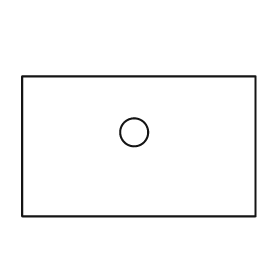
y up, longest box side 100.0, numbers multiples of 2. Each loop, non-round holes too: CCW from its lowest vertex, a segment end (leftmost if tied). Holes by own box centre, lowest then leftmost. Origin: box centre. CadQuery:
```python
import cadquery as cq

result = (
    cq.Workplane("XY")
    .moveTo(-50.0, -30.0)
    .lineTo(50.0, -30.0)
    .lineTo(50.0, 30.0)
    .lineTo(-50.0, 30.0)
    .close()
    .moveTo(-2.0, 6.0)
    .circle(6.0)
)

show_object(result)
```